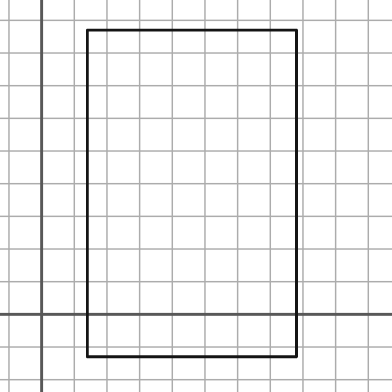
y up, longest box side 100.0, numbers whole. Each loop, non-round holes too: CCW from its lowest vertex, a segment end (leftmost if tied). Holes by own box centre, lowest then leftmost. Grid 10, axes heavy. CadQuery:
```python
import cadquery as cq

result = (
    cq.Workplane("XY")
    .moveTo(14.0, -13.0)
    .lineTo(78.0, -13.0)
    .lineTo(78.0, 87.0)
    .lineTo(14.0, 87.0)
    .close()
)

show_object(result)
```